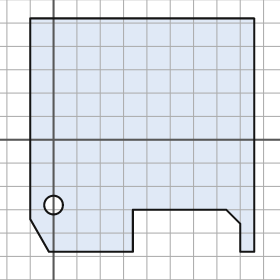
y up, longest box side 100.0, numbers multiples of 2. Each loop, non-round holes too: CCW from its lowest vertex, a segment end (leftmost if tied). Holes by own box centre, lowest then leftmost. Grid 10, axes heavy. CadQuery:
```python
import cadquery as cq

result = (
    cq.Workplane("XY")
    .moveTo(-2.0, -48.0)
    .lineTo(34.0, -48.0)
    .lineTo(34.0, -30.0)
    .lineTo(74.0, -30.0)
    .lineTo(80.0, -36.0)
    .lineTo(80.0, -48.0)
    .lineTo(86.0, -48.0)
    .lineTo(86.0, 52.0)
    .lineTo(-10.0, 52.0)
    .lineTo(-10.0, -34.0)
    .close()
    .moveTo(0.0, -28.0)
    .circle(4.0)
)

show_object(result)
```